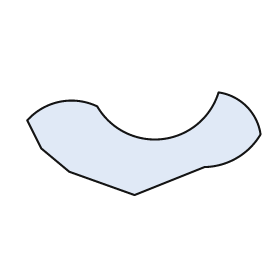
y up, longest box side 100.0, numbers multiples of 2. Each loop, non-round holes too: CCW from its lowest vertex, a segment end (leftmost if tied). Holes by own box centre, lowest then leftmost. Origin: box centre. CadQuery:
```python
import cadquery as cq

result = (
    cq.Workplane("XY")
    .moveTo(-4.0, -22.0)
    .lineTo(26.0, -10.0)
    .threePointArc((40.0, -6.0), (50.0, 4.0))
    .threePointArc((44.0, 16.0), (32.0, 22.0))
    .threePointArc((8.0, 2.0), (-20.0, 16.0))
    .threePointArc((-36.0, 18.0), (-50.0, 10.0))
    .lineTo(-44.0, -2.0)
    .lineTo(-32.0, -12.0)
    .close()
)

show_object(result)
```